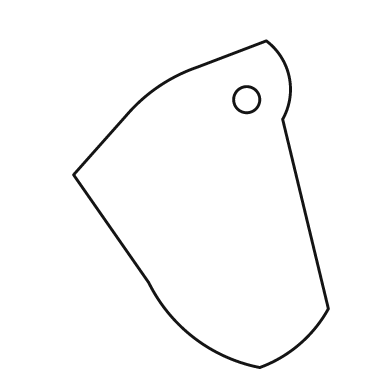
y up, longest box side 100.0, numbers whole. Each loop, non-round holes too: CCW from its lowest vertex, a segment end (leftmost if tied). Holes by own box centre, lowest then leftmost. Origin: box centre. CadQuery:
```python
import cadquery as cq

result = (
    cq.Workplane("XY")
    .moveTo(18.0, -50.0)
    .threePointArc((30.0, -43.0), (39.0, -32.0))
    .lineTo(25.0, 26.0)
    .threePointArc((27.0, 39.0), (20.0, 50.0))
    .lineTo(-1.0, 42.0)
    .threePointArc((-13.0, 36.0), (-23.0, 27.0))
    .lineTo(-39.0, 9.0)
    .lineTo(-16.0, -24.0)
    .threePointArc((-2.0, -41.0), (18.0, -50.0))
    .close()
    .moveTo(14.0, 32.0)
    .circle(4.0)
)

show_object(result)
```